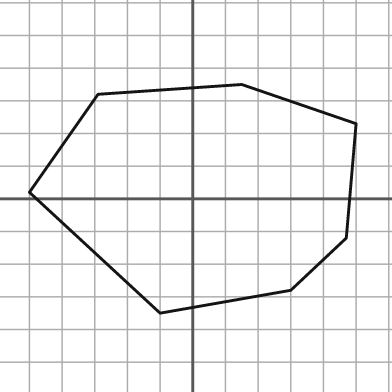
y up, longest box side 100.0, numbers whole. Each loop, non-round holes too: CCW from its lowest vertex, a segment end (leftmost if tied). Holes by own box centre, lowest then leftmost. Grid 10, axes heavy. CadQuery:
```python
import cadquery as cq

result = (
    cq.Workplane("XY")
    .moveTo(-10.0, -35.0)
    .lineTo(30.0, -28.0)
    .lineTo(47.0, -12.0)
    .lineTo(50.0, 23.0)
    .lineTo(15.0, 35.0)
    .lineTo(-29.0, 32.0)
    .lineTo(-50.0, 2.0)
    .close()
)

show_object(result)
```